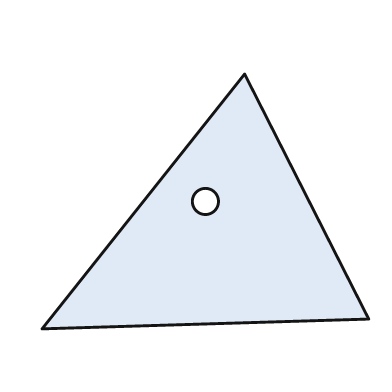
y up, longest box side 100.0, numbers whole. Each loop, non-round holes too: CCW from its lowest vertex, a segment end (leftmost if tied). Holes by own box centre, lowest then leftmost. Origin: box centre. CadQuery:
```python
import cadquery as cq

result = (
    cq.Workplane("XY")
    .moveTo(-50.0, -39.0)
    .lineTo(50.0, -36.0)
    .lineTo(12.0, 39.0)
    .close()
    .moveTo(0.0, 0.0)
    .circle(4.0)
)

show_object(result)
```